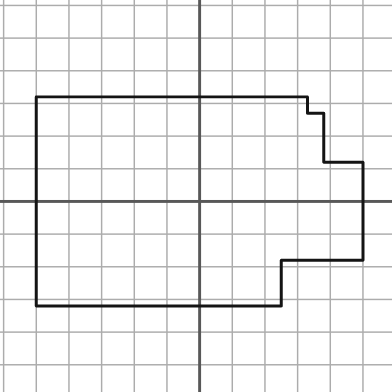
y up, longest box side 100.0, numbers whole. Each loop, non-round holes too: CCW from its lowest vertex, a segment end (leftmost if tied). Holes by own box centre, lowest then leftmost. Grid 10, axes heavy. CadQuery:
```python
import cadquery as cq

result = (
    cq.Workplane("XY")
    .moveTo(-50.0, -32.0)
    .lineTo(25.0, -32.0)
    .lineTo(25.0, -18.0)
    .lineTo(50.0, -18.0)
    .lineTo(50.0, 12.0)
    .lineTo(38.0, 12.0)
    .lineTo(38.0, 27.0)
    .lineTo(33.0, 27.0)
    .lineTo(33.0, 32.0)
    .lineTo(-50.0, 32.0)
    .close()
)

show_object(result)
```